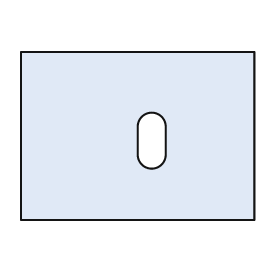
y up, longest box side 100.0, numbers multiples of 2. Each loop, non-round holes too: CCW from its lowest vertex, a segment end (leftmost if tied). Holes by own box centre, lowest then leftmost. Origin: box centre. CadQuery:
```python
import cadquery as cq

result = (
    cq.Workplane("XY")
    .moveTo(-50.0, -36.0)
    .lineTo(50.0, -36.0)
    .lineTo(50.0, 36.0)
    .lineTo(-50.0, 36.0)
    .close()
    .moveTo(0.0, -8.0)
    .threePointArc((6.0, -14.0), (12.0, -8.0))
    .lineTo(12.0, 4.0)
    .threePointArc((6.0, 10.0), (0.0, 4.0))
    .close()
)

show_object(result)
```